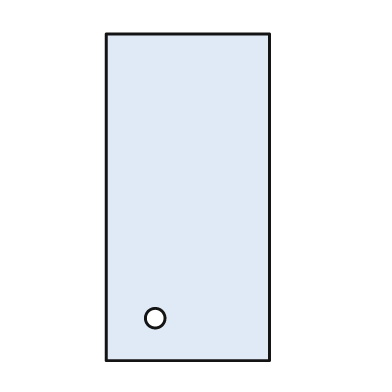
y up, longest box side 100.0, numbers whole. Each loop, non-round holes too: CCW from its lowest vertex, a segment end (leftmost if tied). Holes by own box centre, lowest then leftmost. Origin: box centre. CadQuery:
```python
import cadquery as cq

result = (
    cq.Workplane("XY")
    .moveTo(-25.0, -50.0)
    .lineTo(25.0, -50.0)
    .lineTo(25.0, 50.0)
    .lineTo(-25.0, 50.0)
    .close()
    .moveTo(-10.0, -37.0)
    .circle(3.0)
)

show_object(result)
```